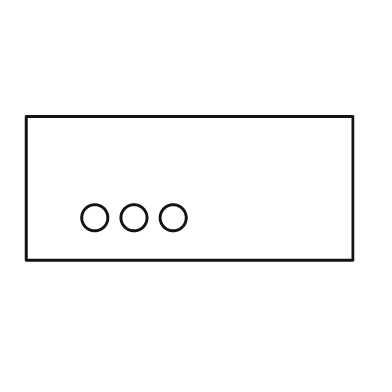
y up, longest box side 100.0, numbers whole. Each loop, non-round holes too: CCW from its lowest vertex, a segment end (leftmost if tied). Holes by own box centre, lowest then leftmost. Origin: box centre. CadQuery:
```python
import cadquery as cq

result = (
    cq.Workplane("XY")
    .moveTo(-50.0, -22.0)
    .lineTo(50.0, -22.0)
    .lineTo(50.0, 22.0)
    .lineTo(-50.0, 22.0)
    .close()
    .moveTo(-29.0, -9.0)
    .circle(4.0)
    .moveTo(-17.0, -9.0)
    .circle(4.0)
    .moveTo(-5.0, -9.0)
    .circle(4.0)
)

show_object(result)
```